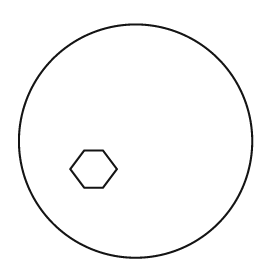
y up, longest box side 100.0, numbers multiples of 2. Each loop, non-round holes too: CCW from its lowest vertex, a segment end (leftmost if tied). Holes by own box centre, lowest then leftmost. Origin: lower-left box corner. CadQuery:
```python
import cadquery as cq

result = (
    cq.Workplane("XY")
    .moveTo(50.0, 50.0)
    .circle(50.0)
    .moveTo(28.0, 30.0)
    .lineTo(36.0, 30.0)
    .lineTo(42.0, 38.0)
    .lineTo(36.0, 46.0)
    .lineTo(28.0, 46.0)
    .lineTo(22.0, 38.0)
    .close()
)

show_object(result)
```